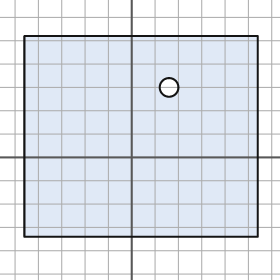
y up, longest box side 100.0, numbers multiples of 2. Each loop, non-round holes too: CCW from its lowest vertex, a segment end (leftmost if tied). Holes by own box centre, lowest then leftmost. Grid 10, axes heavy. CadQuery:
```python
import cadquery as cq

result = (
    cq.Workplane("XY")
    .moveTo(-46.0, -34.0)
    .lineTo(54.0, -34.0)
    .lineTo(54.0, 52.0)
    .lineTo(-46.0, 52.0)
    .close()
    .moveTo(16.0, 30.0)
    .circle(4.0)
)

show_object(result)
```